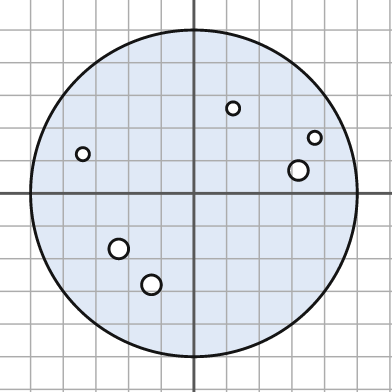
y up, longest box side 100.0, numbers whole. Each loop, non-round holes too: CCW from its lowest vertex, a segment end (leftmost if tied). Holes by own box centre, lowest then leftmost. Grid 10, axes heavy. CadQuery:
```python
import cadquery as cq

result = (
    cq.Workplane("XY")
    .moveTo(0.0, 0.0)
    .circle(50.0)
    .moveTo(-13.0, -28.0)
    .circle(3.0)
    .moveTo(-23.0, -17.0)
    .circle(3.0)
    .moveTo(32.0, 7.0)
    .circle(3.0)
    .moveTo(-34.0, 12.0)
    .circle(2.0)
    .moveTo(37.0, 17.0)
    .circle(2.0)
    .moveTo(12.0, 26.0)
    .circle(2.0)
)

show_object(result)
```